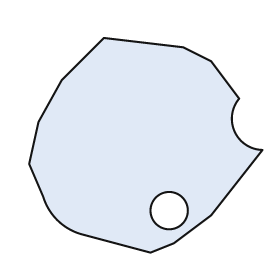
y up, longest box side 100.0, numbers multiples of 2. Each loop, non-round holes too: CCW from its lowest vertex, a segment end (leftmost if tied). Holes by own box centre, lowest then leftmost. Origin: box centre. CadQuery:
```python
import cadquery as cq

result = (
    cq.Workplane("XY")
    .moveTo(2.0, -46.0)
    .lineTo(12.0, -42.0)
    .lineTo(28.0, -30.0)
    .lineTo(50.0, -2.0)
    .threePointArc((38.0, 6.0), (40.0, 20.0))
    .lineTo(28.0, 36.0)
    .lineTo(16.0, 42.0)
    .lineTo(-18.0, 46.0)
    .lineTo(-36.0, 28.0)
    .lineTo(-46.0, 10.0)
    .lineTo(-50.0, -8.0)
    .lineTo(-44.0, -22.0)
    .threePointArc((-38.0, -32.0), (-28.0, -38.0))
    .close()
    .moveTo(10.0, -28.0)
    .circle(8.0)
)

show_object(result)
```